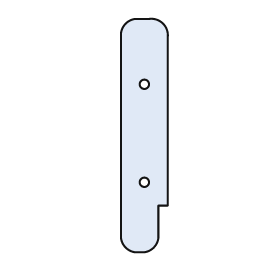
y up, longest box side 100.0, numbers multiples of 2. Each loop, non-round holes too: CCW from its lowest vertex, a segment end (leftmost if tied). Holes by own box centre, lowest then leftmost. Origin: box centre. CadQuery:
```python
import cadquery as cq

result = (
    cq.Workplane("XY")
    .moveTo(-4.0, -50.0)
    .lineTo(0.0, -50.0)
    .threePointArc((4.0, -48.0), (6.0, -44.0))
    .lineTo(6.0, -30.0)
    .lineTo(10.0, -30.0)
    .lineTo(10.0, 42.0)
    .threePointArc((8.0, 48.0), (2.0, 50.0))
    .lineTo(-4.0, 50.0)
    .threePointArc((-8.0, 48.0), (-10.0, 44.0))
    .lineTo(-10.0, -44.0)
    .threePointArc((-8.0, -48.0), (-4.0, -50.0))
    .close()
    .moveTo(0.0, -20.0)
    .circle(2.0)
    .moveTo(0.0, 22.0)
    .circle(2.0)
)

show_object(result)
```